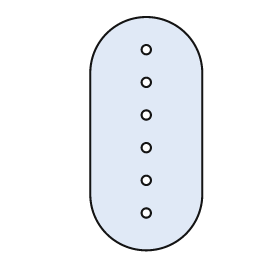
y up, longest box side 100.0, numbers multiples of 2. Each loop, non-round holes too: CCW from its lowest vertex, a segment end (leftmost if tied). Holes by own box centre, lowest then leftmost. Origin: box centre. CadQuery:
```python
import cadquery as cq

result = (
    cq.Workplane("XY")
    .moveTo(-24.0, -26.0)
    .threePointArc((0.0, -50.0), (24.0, -26.0))
    .lineTo(24.0, 26.0)
    .threePointArc((0.0, 50.0), (-24.0, 26.0))
    .close()
    .moveTo(0.0, -34.0)
    .circle(2.0)
    .moveTo(0.0, -20.0)
    .circle(2.0)
    .moveTo(0.0, -6.0)
    .circle(2.0)
    .moveTo(0.0, 8.0)
    .circle(2.0)
    .moveTo(0.0, 22.0)
    .circle(2.0)
    .moveTo(0.0, 36.0)
    .circle(2.0)
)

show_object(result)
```